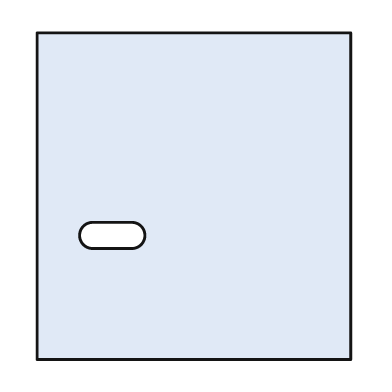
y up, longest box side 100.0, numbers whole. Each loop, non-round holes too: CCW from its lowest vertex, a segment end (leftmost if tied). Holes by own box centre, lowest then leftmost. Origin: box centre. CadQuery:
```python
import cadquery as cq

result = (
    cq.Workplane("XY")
    .moveTo(-48.0, -50.0)
    .lineTo(48.0, -50.0)
    .lineTo(48.0, 50.0)
    .lineTo(-48.0, 50.0)
    .close()
    .moveTo(-31.0, -16.0)
    .lineTo(-19.0, -16.0)
    .threePointArc((-15.0, -12.0), (-19.0, -8.0))
    .lineTo(-31.0, -8.0)
    .threePointArc((-35.0, -12.0), (-31.0, -16.0))
    .close()
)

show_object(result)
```